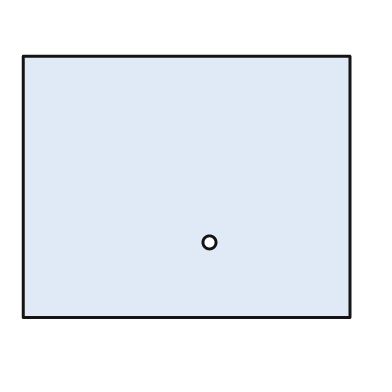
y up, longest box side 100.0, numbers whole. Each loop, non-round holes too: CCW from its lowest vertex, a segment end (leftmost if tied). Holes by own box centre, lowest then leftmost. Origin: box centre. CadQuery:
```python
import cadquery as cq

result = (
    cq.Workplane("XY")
    .moveTo(-50.0, -40.0)
    .lineTo(50.0, -40.0)
    .lineTo(50.0, 40.0)
    .lineTo(-50.0, 40.0)
    .close()
    .moveTo(7.0, -17.0)
    .circle(2.0)
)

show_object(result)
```